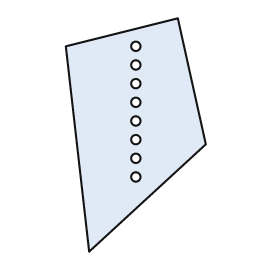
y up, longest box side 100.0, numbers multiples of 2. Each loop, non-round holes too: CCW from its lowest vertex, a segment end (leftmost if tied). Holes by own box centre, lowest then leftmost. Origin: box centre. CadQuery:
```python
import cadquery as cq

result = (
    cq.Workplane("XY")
    .moveTo(-20.0, -50.0)
    .lineTo(30.0, -4.0)
    .lineTo(18.0, 50.0)
    .lineTo(-30.0, 38.0)
    .close()
    .moveTo(0.0, -18.0)
    .circle(2.0)
    .moveTo(0.0, -10.0)
    .circle(2.0)
    .moveTo(0.0, -2.0)
    .circle(2.0)
    .moveTo(0.0, 6.0)
    .circle(2.0)
    .moveTo(0.0, 14.0)
    .circle(2.0)
    .moveTo(0.0, 22.0)
    .circle(2.0)
    .moveTo(0.0, 30.0)
    .circle(2.0)
    .moveTo(0.0, 38.0)
    .circle(2.0)
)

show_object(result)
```